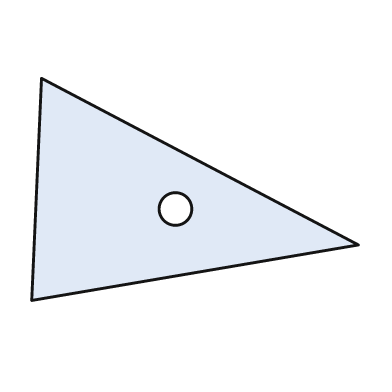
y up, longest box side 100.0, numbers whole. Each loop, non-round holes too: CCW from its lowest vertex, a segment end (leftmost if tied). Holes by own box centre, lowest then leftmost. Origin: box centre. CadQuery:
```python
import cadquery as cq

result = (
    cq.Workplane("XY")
    .moveTo(-50.0, -34.0)
    .lineTo(50.0, -17.0)
    .lineTo(-47.0, 34.0)
    .close()
    .moveTo(-6.0, -6.0)
    .circle(5.0)
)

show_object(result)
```